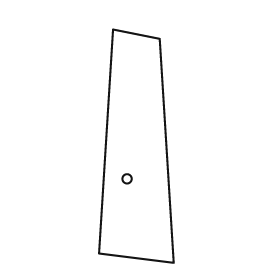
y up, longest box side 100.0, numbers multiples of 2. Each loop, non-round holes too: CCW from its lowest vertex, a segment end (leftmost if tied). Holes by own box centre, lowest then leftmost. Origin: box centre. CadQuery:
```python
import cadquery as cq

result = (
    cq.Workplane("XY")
    .moveTo(16.0, -50.0)
    .lineTo(10.0, 46.0)
    .lineTo(-10.0, 50.0)
    .lineTo(-16.0, -46.0)
    .close()
    .moveTo(-4.0, -14.0)
    .circle(2.0)
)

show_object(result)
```